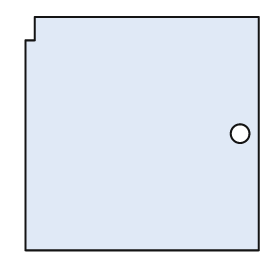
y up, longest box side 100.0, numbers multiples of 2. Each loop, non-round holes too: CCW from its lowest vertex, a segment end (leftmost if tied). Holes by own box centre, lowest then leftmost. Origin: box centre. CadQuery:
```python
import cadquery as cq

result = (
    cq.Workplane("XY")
    .moveTo(-50.0, -50.0)
    .lineTo(50.0, -50.0)
    .lineTo(50.0, 50.0)
    .lineTo(-46.0, 50.0)
    .lineTo(-46.0, 40.0)
    .lineTo(-50.0, 40.0)
    .close()
    .moveTo(42.0, 0.0)
    .circle(4.0)
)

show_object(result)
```